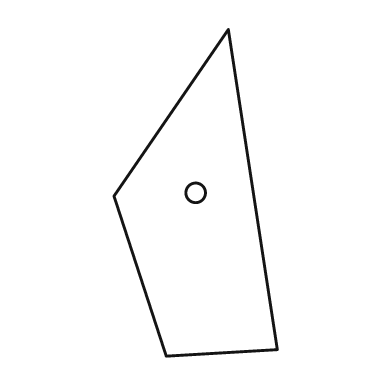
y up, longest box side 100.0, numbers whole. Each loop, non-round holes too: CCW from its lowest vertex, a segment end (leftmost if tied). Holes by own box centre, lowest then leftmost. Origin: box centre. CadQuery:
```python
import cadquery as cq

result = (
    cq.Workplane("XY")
    .moveTo(-9.0, -50.0)
    .lineTo(25.0, -48.0)
    .lineTo(10.0, 50.0)
    .lineTo(-25.0, -1.0)
    .close()
    .moveTo(0.0, 0.0)
    .circle(3.0)
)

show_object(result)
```